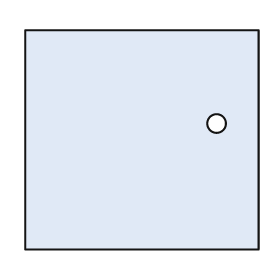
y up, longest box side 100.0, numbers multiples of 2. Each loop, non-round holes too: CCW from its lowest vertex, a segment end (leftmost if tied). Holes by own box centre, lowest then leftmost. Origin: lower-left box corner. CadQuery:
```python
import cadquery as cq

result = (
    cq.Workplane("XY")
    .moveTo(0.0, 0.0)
    .lineTo(100.0, 0.0)
    .lineTo(100.0, 94.0)
    .lineTo(0.0, 94.0)
    .close()
    .moveTo(82.0, 54.0)
    .circle(4.0)
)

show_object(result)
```